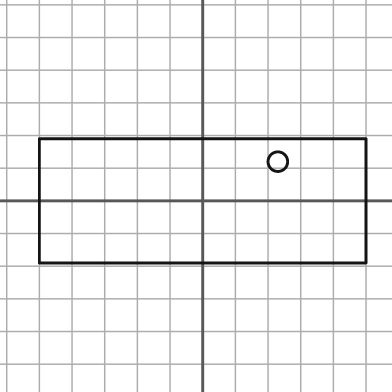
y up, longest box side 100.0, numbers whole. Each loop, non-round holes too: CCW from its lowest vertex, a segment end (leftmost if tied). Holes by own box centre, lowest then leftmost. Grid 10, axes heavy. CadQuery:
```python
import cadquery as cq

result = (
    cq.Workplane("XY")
    .moveTo(-50.0, -19.0)
    .lineTo(50.0, -19.0)
    .lineTo(50.0, 19.0)
    .lineTo(-50.0, 19.0)
    .close()
    .moveTo(23.0, 12.0)
    .circle(3.0)
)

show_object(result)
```